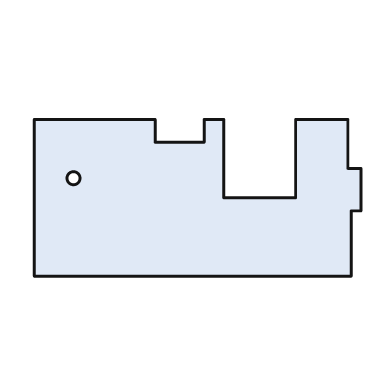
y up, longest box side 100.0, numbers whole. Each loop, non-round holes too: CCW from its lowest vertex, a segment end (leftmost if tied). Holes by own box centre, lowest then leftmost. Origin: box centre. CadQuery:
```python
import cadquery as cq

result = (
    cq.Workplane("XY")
    .moveTo(-50.0, -24.0)
    .lineTo(47.0, -24.0)
    .lineTo(47.0, -4.0)
    .lineTo(50.0, -4.0)
    .lineTo(50.0, 9.0)
    .lineTo(46.0, 9.0)
    .lineTo(46.0, 24.0)
    .lineTo(30.0, 24.0)
    .lineTo(30.0, 0.0)
    .lineTo(8.0, 0.0)
    .lineTo(8.0, 24.0)
    .lineTo(2.0, 24.0)
    .lineTo(2.0, 17.0)
    .lineTo(-13.0, 17.0)
    .lineTo(-13.0, 24.0)
    .lineTo(-50.0, 24.0)
    .close()
    .moveTo(-38.0, 6.0)
    .circle(2.0)
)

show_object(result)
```